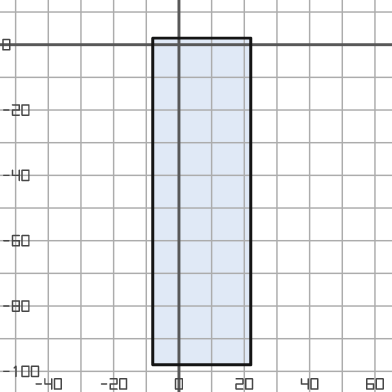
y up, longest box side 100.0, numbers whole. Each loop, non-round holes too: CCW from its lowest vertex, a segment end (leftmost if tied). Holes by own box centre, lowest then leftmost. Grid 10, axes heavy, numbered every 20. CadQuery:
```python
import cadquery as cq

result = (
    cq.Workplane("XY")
    .moveTo(-8.0, -98.0)
    .lineTo(22.0, -98.0)
    .lineTo(22.0, 2.0)
    .lineTo(-8.0, 2.0)
    .close()
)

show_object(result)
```